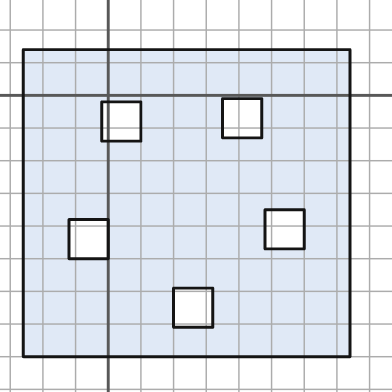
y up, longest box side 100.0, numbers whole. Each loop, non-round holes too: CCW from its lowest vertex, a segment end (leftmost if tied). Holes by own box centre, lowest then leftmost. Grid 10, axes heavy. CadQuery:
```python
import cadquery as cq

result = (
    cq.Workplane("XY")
    .moveTo(-26.0, -80.0)
    .lineTo(74.0, -80.0)
    .lineTo(74.0, 14.0)
    .lineTo(-26.0, 14.0)
    .close()
    .moveTo(20.0, -71.0)
    .lineTo(32.0, -71.0)
    .lineTo(32.0, -59.0)
    .lineTo(20.0, -59.0)
    .close()
    .moveTo(-12.0, -50.0)
    .lineTo(0.0, -50.0)
    .lineTo(0.0, -38.0)
    .lineTo(-12.0, -38.0)
    .close()
    .moveTo(48.0, -47.0)
    .lineTo(60.0, -47.0)
    .lineTo(60.0, -35.0)
    .lineTo(48.0, -35.0)
    .close()
    .moveTo(-2.0, -14.0)
    .lineTo(10.0, -14.0)
    .lineTo(10.0, -2.0)
    .lineTo(-2.0, -2.0)
    .close()
    .moveTo(35.0, -13.0)
    .lineTo(47.0, -13.0)
    .lineTo(47.0, -1.0)
    .lineTo(35.0, -1.0)
    .close()
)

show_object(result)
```